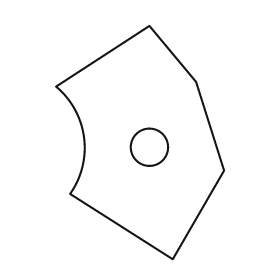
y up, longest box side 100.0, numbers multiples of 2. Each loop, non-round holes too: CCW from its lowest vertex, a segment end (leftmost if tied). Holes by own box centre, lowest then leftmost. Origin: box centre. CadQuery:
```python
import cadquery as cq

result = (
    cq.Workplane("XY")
    .moveTo(14.0, -50.0)
    .lineTo(36.0, -12.0)
    .lineTo(24.0, 26.0)
    .lineTo(4.0, 50.0)
    .lineTo(-36.0, 24.0)
    .threePointArc((-24.0, 2.0), (-30.0, -22.0))
    .close()
    .moveTo(4.0, -2.0)
    .circle(8.0)
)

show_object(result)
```